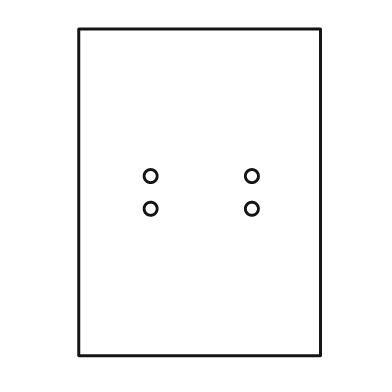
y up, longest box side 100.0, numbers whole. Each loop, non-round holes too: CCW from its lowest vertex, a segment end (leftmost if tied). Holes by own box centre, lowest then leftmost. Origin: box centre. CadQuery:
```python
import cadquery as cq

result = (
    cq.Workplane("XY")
    .moveTo(-37.0, -50.0)
    .lineTo(37.0, -50.0)
    .lineTo(37.0, 50.0)
    .lineTo(-37.0, 50.0)
    .close()
    .moveTo(-15.0, -5.0)
    .circle(2.0)
    .moveTo(16.0, -5.0)
    .circle(2.0)
    .moveTo(-15.0, 5.0)
    .circle(2.0)
    .moveTo(16.0, 5.0)
    .circle(2.0)
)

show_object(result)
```